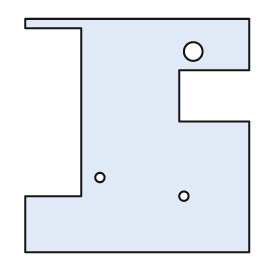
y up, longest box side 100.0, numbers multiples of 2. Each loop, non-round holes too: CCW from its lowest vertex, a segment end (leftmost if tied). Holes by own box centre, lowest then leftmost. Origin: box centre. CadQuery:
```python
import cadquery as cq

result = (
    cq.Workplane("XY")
    .moveTo(-48.0, -50.0)
    .lineTo(48.0, -50.0)
    .lineTo(48.0, 6.0)
    .lineTo(18.0, 6.0)
    .lineTo(18.0, 28.0)
    .lineTo(48.0, 28.0)
    .lineTo(48.0, 50.0)
    .lineTo(-48.0, 50.0)
    .lineTo(-48.0, 46.0)
    .lineTo(-24.0, 46.0)
    .lineTo(-24.0, -26.0)
    .lineTo(-48.0, -26.0)
    .close()
    .moveTo(20.0, -26.0)
    .circle(2.0)
    .moveTo(-16.0, -18.0)
    .circle(2.0)
    .moveTo(24.0, 36.0)
    .circle(4.0)
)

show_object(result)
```